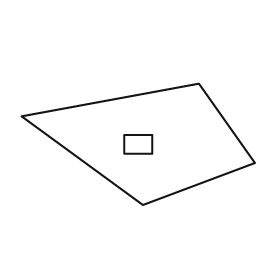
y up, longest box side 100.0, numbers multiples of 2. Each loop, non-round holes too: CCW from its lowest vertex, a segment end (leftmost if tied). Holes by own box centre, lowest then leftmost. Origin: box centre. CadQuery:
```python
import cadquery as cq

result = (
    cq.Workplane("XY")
    .moveTo(2.0, -26.0)
    .lineTo(50.0, -8.0)
    .lineTo(26.0, 26.0)
    .lineTo(-50.0, 12.0)
    .close()
    .moveTo(-6.0, -4.0)
    .lineTo(6.0, -4.0)
    .lineTo(6.0, 4.0)
    .lineTo(-6.0, 4.0)
    .close()
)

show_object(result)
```